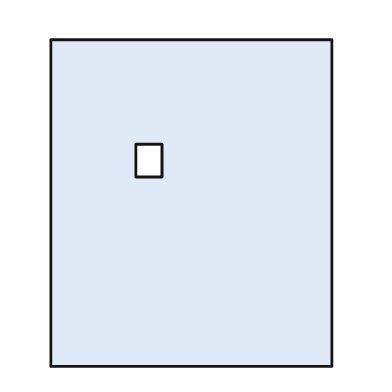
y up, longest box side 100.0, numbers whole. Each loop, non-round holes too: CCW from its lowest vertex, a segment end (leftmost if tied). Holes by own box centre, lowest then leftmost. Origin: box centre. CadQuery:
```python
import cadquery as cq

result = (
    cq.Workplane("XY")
    .moveTo(-43.0, -50.0)
    .lineTo(43.0, -50.0)
    .lineTo(43.0, 50.0)
    .lineTo(-43.0, 50.0)
    .close()
    .moveTo(-17.0, 8.0)
    .lineTo(-9.0, 8.0)
    .lineTo(-9.0, 18.0)
    .lineTo(-17.0, 18.0)
    .close()
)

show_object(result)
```